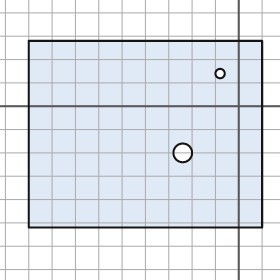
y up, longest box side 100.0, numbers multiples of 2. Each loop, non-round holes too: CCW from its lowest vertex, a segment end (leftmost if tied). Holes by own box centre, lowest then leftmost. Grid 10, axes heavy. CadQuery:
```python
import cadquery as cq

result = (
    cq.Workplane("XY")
    .moveTo(-90.0, -52.0)
    .lineTo(10.0, -52.0)
    .lineTo(10.0, 28.0)
    .lineTo(-90.0, 28.0)
    .close()
    .moveTo(-24.0, -20.0)
    .circle(4.0)
    .moveTo(-8.0, 14.0)
    .circle(2.0)
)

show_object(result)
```